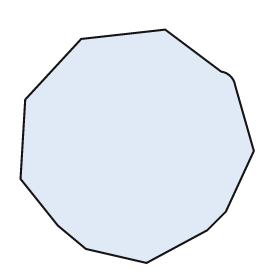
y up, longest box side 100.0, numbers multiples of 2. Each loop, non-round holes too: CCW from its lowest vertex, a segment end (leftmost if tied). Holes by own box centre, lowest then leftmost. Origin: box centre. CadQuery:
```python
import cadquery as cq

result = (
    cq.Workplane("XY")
    .moveTo(4.0, -50.0)
    .lineTo(30.0, -36.0)
    .lineTo(38.0, -28.0)
    .lineTo(50.0, -2.0)
    .lineTo(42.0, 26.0)
    .threePointArc((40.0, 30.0), (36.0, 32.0))
    .lineTo(12.0, 50.0)
    .lineTo(-24.0, 46.0)
    .lineTo(-48.0, 20.0)
    .lineTo(-50.0, -14.0)
    .lineTo(-34.0, -34.0)
    .lineTo(-22.0, -44.0)
    .close()
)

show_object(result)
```